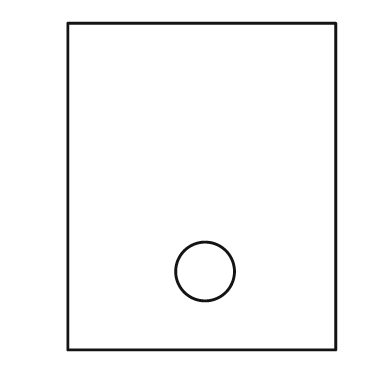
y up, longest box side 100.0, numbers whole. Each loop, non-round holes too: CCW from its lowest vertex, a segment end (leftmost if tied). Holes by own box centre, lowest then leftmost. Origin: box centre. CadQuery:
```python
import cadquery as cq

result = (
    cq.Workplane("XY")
    .moveTo(-41.0, -50.0)
    .lineTo(41.0, -50.0)
    .lineTo(41.0, 50.0)
    .lineTo(-41.0, 50.0)
    .close()
    .moveTo(1.0, -26.0)
    .circle(9.0)
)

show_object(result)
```